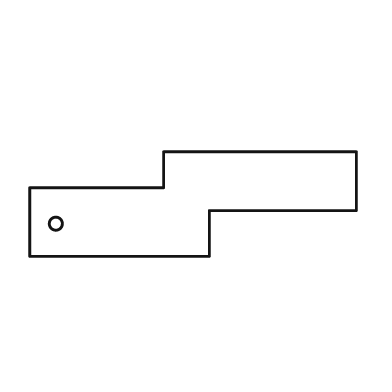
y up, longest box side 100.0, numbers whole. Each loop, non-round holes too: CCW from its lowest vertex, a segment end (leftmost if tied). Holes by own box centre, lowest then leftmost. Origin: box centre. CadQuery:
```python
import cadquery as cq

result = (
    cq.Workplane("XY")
    .moveTo(-50.0, -16.0)
    .lineTo(5.0, -16.0)
    .lineTo(5.0, -2.0)
    .lineTo(50.0, -2.0)
    .lineTo(50.0, 16.0)
    .lineTo(-9.0, 16.0)
    .lineTo(-9.0, 5.0)
    .lineTo(-50.0, 5.0)
    .close()
    .moveTo(-42.0, -6.0)
    .circle(2.0)
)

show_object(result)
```